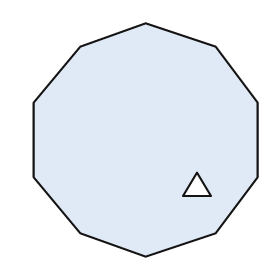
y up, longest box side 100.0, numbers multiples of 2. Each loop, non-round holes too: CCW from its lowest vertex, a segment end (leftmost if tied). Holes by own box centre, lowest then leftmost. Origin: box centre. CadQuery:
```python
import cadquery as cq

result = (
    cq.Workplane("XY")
    .moveTo(0.0, -50.0)
    .lineTo(30.0, -40.0)
    .lineTo(48.0, -16.0)
    .lineTo(48.0, 16.0)
    .lineTo(30.0, 40.0)
    .lineTo(0.0, 50.0)
    .lineTo(-28.0, 40.0)
    .lineTo(-48.0, 16.0)
    .lineTo(-48.0, -16.0)
    .lineTo(-28.0, -40.0)
    .close()
    .moveTo(16.0, -24.0)
    .lineTo(28.0, -24.0)
    .lineTo(22.0, -14.0)
    .close()
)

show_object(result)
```